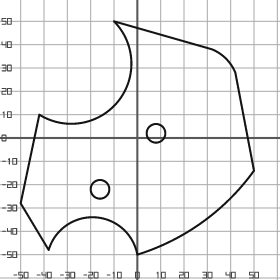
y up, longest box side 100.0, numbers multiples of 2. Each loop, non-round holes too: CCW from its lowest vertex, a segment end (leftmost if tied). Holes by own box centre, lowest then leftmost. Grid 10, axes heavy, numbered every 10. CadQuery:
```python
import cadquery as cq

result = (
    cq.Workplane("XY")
    .moveTo(0.0, -50.0)
    .threePointArc((28.0, -36.0), (50.0, -14.0))
    .lineTo(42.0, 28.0)
    .threePointArc((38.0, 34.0), (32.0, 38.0))
    .lineTo(-10.0, 50.0)
    .threePointArc((-8.0, 16.0), (-42.0, 10.0))
    .lineTo(-50.0, -28.0)
    .lineTo(-38.0, -48.0)
    .threePointArc((-18.0, -34.0), (0.0, -50.0))
    .close()
    .moveTo(-16.0, -22.0)
    .circle(4.0)
    .moveTo(8.0, 2.0)
    .circle(4.0)
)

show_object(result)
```